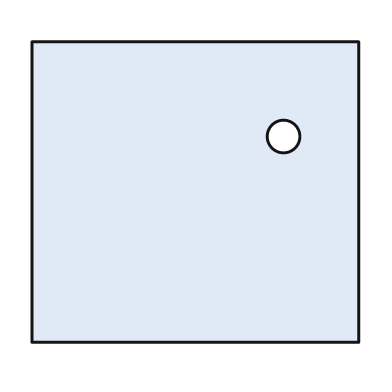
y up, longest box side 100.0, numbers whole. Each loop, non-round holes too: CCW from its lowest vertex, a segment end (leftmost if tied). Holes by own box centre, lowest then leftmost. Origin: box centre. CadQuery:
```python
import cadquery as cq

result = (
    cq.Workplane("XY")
    .moveTo(-50.0, -46.0)
    .lineTo(50.0, -46.0)
    .lineTo(50.0, 46.0)
    .lineTo(-50.0, 46.0)
    .close()
    .moveTo(27.0, 17.0)
    .circle(5.0)
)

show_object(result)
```